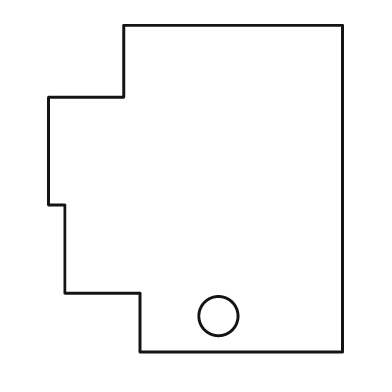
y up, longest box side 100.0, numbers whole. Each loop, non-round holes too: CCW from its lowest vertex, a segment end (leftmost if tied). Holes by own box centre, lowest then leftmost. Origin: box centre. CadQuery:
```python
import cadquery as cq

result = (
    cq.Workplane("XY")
    .moveTo(-17.0, -50.0)
    .lineTo(45.0, -50.0)
    .lineTo(45.0, 50.0)
    .lineTo(-22.0, 50.0)
    .lineTo(-22.0, 28.0)
    .lineTo(-45.0, 28.0)
    .lineTo(-45.0, -5.0)
    .lineTo(-40.0, -5.0)
    .lineTo(-40.0, -32.0)
    .lineTo(-17.0, -32.0)
    .close()
    .moveTo(7.0, -39.0)
    .circle(6.0)
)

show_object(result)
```